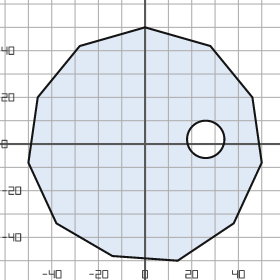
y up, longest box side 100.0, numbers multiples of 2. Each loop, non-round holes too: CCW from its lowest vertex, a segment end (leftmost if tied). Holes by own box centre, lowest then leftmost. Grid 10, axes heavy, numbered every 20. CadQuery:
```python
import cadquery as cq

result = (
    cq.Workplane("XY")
    .moveTo(14.0, -50.0)
    .lineTo(38.0, -34.0)
    .lineTo(50.0, -8.0)
    .lineTo(46.0, 20.0)
    .lineTo(28.0, 42.0)
    .lineTo(0.0, 50.0)
    .lineTo(-28.0, 42.0)
    .lineTo(-46.0, 20.0)
    .lineTo(-50.0, -8.0)
    .lineTo(-38.0, -34.0)
    .lineTo(-14.0, -48.0)
    .close()
    .moveTo(26.0, 2.0)
    .circle(8.0)
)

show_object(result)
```